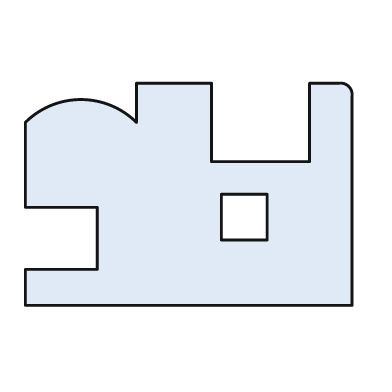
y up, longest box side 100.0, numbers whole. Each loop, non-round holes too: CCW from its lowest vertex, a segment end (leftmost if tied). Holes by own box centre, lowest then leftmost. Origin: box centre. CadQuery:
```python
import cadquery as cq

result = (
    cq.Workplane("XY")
    .moveTo(-50.0, -34.0)
    .lineTo(50.0, -34.0)
    .lineTo(50.0, 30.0)
    .threePointArc((49.0, 33.0), (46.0, 34.0))
    .lineTo(37.0, 34.0)
    .lineTo(37.0, 10.0)
    .lineTo(7.0, 10.0)
    .lineTo(7.0, 34.0)
    .lineTo(-16.0, 34.0)
    .lineTo(-16.0, 22.0)
    .threePointArc((-33.0, 29.0), (-50.0, 22.0))
    .lineTo(-50.0, -4.0)
    .lineTo(-28.0, -4.0)
    .lineTo(-28.0, -23.0)
    .lineTo(-50.0, -23.0)
    .close()
    .moveTo(10.0, -14.0)
    .lineTo(24.0, -14.0)
    .lineTo(24.0, 0.0)
    .lineTo(10.0, 0.0)
    .close()
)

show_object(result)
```